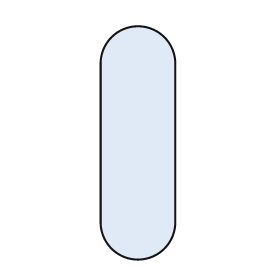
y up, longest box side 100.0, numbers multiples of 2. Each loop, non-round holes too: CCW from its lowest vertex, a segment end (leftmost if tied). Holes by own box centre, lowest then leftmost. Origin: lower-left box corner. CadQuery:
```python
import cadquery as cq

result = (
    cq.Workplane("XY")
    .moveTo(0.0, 16.0)
    .threePointArc((16.0, 0.0), (32.0, 16.0))
    .lineTo(32.0, 84.0)
    .threePointArc((16.0, 100.0), (0.0, 84.0))
    .close()
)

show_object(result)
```